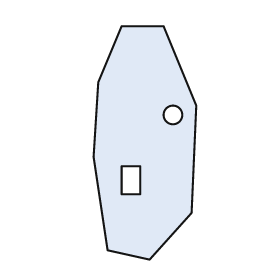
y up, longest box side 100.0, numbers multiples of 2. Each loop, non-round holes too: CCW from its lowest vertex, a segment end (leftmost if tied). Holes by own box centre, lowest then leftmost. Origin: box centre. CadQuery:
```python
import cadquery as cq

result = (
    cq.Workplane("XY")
    .moveTo(2.0, -50.0)
    .lineTo(20.0, -30.0)
    .lineTo(22.0, 16.0)
    .lineTo(8.0, 50.0)
    .lineTo(-10.0, 50.0)
    .lineTo(-20.0, 26.0)
    .lineTo(-22.0, -6.0)
    .lineTo(-16.0, -46.0)
    .close()
    .moveTo(-10.0, -22.0)
    .lineTo(-2.0, -22.0)
    .lineTo(-2.0, -10.0)
    .lineTo(-10.0, -10.0)
    .close()
    .moveTo(12.0, 12.0)
    .circle(4.0)
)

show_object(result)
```